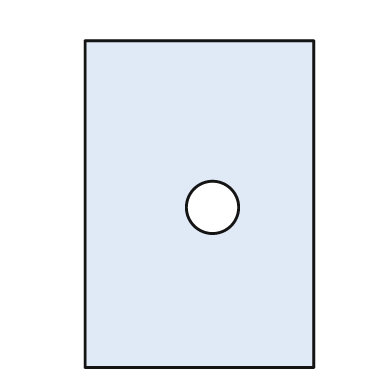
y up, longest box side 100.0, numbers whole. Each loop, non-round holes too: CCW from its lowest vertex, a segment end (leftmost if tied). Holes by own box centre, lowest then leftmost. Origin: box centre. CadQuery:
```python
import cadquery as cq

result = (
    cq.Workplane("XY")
    .moveTo(-35.0, -50.0)
    .lineTo(35.0, -50.0)
    .lineTo(35.0, 50.0)
    .lineTo(-35.0, 50.0)
    .close()
    .moveTo(4.0, -1.0)
    .circle(8.0)
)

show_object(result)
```